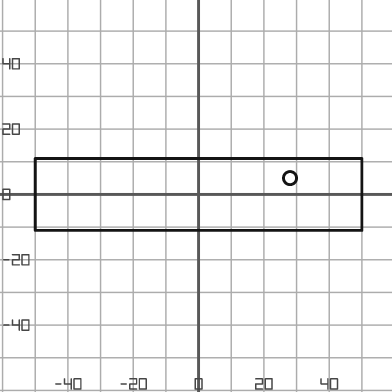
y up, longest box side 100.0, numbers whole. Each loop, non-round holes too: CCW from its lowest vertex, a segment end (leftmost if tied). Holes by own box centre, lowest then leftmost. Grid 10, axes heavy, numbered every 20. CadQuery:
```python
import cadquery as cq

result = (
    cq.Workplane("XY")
    .moveTo(-50.0, -11.0)
    .lineTo(50.0, -11.0)
    .lineTo(50.0, 11.0)
    .lineTo(-50.0, 11.0)
    .close()
    .moveTo(28.0, 5.0)
    .circle(2.0)
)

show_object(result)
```